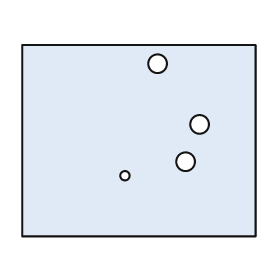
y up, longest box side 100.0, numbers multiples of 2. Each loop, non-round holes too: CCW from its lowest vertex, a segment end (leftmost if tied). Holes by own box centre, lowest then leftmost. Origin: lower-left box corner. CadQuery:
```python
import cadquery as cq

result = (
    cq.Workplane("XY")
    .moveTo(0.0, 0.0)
    .lineTo(100.0, 0.0)
    .lineTo(100.0, 82.0)
    .lineTo(0.0, 82.0)
    .close()
    .moveTo(44.0, 26.0)
    .circle(2.0)
    .moveTo(70.0, 32.0)
    .circle(4.0)
    .moveTo(76.0, 48.0)
    .circle(4.0)
    .moveTo(58.0, 74.0)
    .circle(4.0)
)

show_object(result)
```